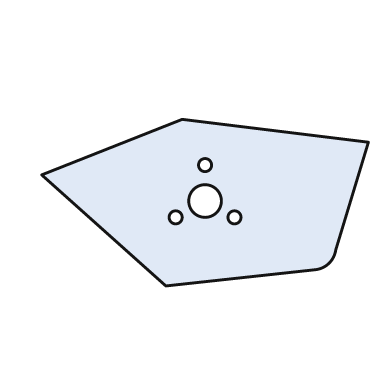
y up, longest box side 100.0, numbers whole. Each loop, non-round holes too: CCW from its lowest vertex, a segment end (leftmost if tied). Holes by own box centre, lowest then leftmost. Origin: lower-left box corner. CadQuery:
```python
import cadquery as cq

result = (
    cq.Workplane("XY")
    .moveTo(38.0, 0.0)
    .lineTo(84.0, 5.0)
    .threePointArc((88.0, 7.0), (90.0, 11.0))
    .lineTo(100.0, 44.0)
    .lineTo(43.0, 51.0)
    .lineTo(0.0, 34.0)
    .close()
    .moveTo(41.0, 21.0)
    .circle(2.0)
    .moveTo(59.0, 21.0)
    .circle(2.0)
    .moveTo(50.0, 26.0)
    .circle(5.0)
    .moveTo(50.0, 37.0)
    .circle(2.0)
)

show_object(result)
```